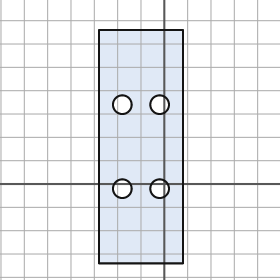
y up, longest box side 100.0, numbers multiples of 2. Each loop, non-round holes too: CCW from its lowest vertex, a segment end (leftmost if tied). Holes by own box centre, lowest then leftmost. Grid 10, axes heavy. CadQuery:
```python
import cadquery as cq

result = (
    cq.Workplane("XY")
    .moveTo(-28.0, -34.0)
    .lineTo(8.0, -34.0)
    .lineTo(8.0, 66.0)
    .lineTo(-28.0, 66.0)
    .close()
    .moveTo(-18.0, -2.0)
    .circle(4.0)
    .moveTo(-2.0, -2.0)
    .circle(4.0)
    .moveTo(-18.0, 34.0)
    .circle(4.0)
    .moveTo(-2.0, 34.0)
    .circle(4.0)
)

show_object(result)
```